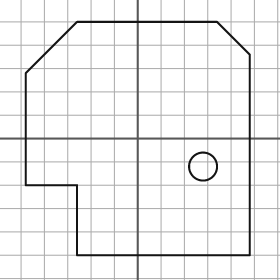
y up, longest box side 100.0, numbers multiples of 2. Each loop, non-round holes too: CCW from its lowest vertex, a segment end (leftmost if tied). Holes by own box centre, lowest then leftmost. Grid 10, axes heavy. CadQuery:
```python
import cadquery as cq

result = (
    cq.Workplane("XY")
    .moveTo(-26.0, -50.0)
    .lineTo(48.0, -50.0)
    .lineTo(48.0, 36.0)
    .lineTo(34.0, 50.0)
    .lineTo(-26.0, 50.0)
    .lineTo(-48.0, 28.0)
    .lineTo(-48.0, -20.0)
    .lineTo(-26.0, -20.0)
    .close()
    .moveTo(28.0, -12.0)
    .circle(6.0)
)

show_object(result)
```